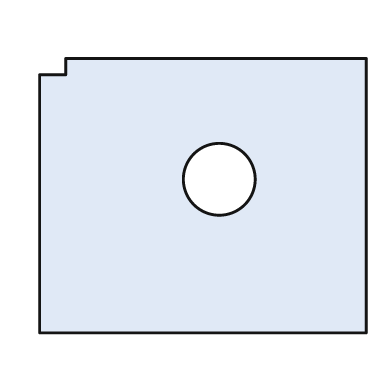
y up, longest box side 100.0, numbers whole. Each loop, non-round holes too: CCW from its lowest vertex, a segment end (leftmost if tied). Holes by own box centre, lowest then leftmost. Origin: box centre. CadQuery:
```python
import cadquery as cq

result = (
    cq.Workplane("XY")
    .moveTo(-50.0, -42.0)
    .lineTo(50.0, -42.0)
    .lineTo(50.0, 42.0)
    .lineTo(-42.0, 42.0)
    .lineTo(-42.0, 37.0)
    .lineTo(-50.0, 37.0)
    .close()
    .moveTo(5.0, 5.0)
    .circle(11.0)
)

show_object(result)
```